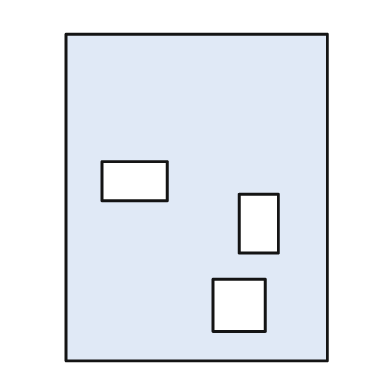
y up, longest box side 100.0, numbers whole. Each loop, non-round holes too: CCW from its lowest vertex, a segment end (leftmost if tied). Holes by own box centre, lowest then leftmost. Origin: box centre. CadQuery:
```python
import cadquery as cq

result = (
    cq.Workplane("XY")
    .moveTo(-40.0, -50.0)
    .lineTo(40.0, -50.0)
    .lineTo(40.0, 50.0)
    .lineTo(-40.0, 50.0)
    .close()
    .moveTo(5.0, -41.0)
    .lineTo(21.0, -41.0)
    .lineTo(21.0, -25.0)
    .lineTo(5.0, -25.0)
    .close()
    .moveTo(13.0, -17.0)
    .lineTo(25.0, -17.0)
    .lineTo(25.0, 1.0)
    .lineTo(13.0, 1.0)
    .close()
    .moveTo(-29.0, -1.0)
    .lineTo(-9.0, -1.0)
    .lineTo(-9.0, 11.0)
    .lineTo(-29.0, 11.0)
    .close()
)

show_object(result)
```